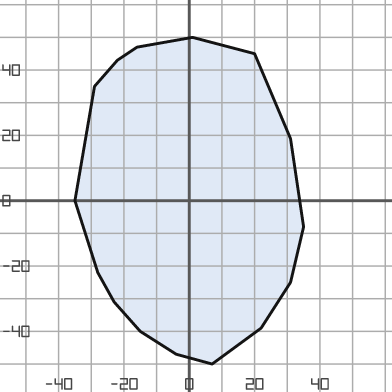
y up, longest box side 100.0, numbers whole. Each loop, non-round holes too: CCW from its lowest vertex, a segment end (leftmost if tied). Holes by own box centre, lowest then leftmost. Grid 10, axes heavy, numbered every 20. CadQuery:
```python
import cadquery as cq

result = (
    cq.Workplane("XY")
    .moveTo(7.0, -50.0)
    .lineTo(22.0, -39.0)
    .lineTo(31.0, -25.0)
    .lineTo(35.0, -8.0)
    .lineTo(31.0, 19.0)
    .lineTo(20.0, 45.0)
    .lineTo(1.0, 50.0)
    .lineTo(-16.0, 47.0)
    .lineTo(-22.0, 43.0)
    .lineTo(-29.0, 35.0)
    .lineTo(-35.0, 0.0)
    .lineTo(-28.0, -22.0)
    .lineTo(-23.0, -31.0)
    .lineTo(-15.0, -40.0)
    .lineTo(-4.0, -47.0)
    .close()
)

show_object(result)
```